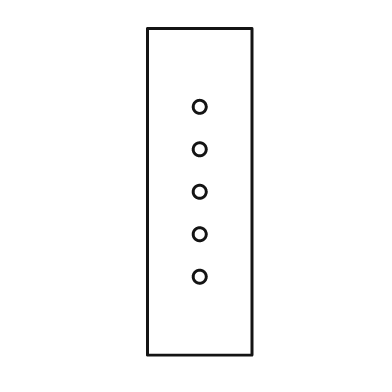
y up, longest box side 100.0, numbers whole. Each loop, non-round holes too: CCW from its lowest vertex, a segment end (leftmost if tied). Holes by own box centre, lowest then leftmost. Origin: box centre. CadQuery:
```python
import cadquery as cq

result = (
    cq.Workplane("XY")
    .moveTo(-16.0, -50.0)
    .lineTo(16.0, -50.0)
    .lineTo(16.0, 50.0)
    .lineTo(-16.0, 50.0)
    .close()
    .moveTo(0.0, -26.0)
    .circle(2.0)
    .moveTo(0.0, -13.0)
    .circle(2.0)
    .moveTo(0.0, 0.0)
    .circle(2.0)
    .moveTo(0.0, 13.0)
    .circle(2.0)
    .moveTo(0.0, 26.0)
    .circle(2.0)
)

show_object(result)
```